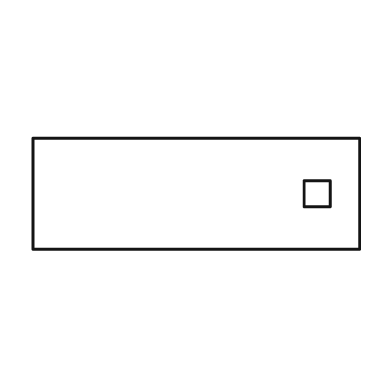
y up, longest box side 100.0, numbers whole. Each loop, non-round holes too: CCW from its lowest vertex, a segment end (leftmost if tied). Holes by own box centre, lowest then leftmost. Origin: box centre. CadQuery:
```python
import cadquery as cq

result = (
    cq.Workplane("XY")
    .moveTo(-50.0, -17.0)
    .lineTo(50.0, -17.0)
    .lineTo(50.0, 17.0)
    .lineTo(-50.0, 17.0)
    .close()
    .moveTo(33.0, -4.0)
    .lineTo(41.0, -4.0)
    .lineTo(41.0, 4.0)
    .lineTo(33.0, 4.0)
    .close()
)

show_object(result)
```